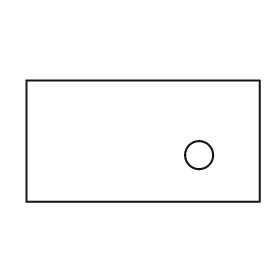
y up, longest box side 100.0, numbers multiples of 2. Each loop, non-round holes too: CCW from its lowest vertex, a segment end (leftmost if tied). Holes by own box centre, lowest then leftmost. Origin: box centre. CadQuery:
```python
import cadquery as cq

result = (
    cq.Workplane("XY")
    .moveTo(-50.0, -26.0)
    .lineTo(50.0, -26.0)
    .lineTo(50.0, 26.0)
    .lineTo(-50.0, 26.0)
    .close()
    .moveTo(24.0, -6.0)
    .circle(6.0)
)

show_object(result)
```